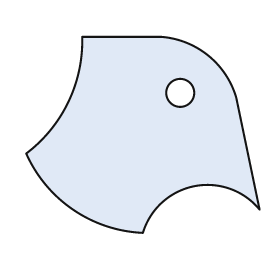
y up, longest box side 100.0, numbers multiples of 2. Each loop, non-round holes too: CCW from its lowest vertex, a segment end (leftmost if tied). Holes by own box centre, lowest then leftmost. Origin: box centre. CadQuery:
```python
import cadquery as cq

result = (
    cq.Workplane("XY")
    .moveTo(0.0, -42.0)
    .threePointArc((22.0, -22.0), (50.0, -32.0))
    .lineTo(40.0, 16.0)
    .threePointArc((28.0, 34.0), (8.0, 42.0))
    .lineTo(-26.0, 42.0)
    .threePointArc((-32.0, 14.0), (-50.0, -8.0))
    .threePointArc((-30.0, -32.0), (0.0, -42.0))
    .close()
    .moveTo(16.0, 18.0)
    .circle(6.0)
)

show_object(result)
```